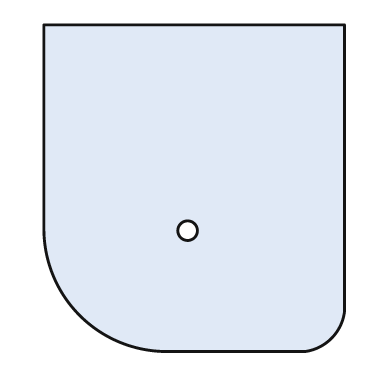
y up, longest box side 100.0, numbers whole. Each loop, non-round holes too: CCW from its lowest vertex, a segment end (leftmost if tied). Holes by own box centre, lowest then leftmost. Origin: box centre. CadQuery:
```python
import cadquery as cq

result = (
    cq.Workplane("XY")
    .moveTo(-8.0, -50.0)
    .lineTo(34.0, -50.0)
    .threePointArc((42.0, -46.0), (46.0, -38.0))
    .lineTo(46.0, 50.0)
    .lineTo(-46.0, 50.0)
    .lineTo(-46.0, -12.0)
    .threePointArc((-35.0, -39.0), (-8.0, -50.0))
    .close()
    .moveTo(-2.0, -13.0)
    .circle(3.0)
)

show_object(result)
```